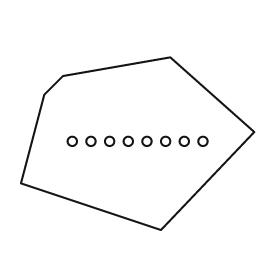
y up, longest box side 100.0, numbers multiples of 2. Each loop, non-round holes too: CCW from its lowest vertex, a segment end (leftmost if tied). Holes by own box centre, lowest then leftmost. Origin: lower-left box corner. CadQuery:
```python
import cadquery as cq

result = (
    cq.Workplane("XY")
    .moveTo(60.0, 0.0)
    .lineTo(100.0, 42.0)
    .lineTo(64.0, 74.0)
    .lineTo(18.0, 66.0)
    .lineTo(10.0, 58.0)
    .lineTo(0.0, 20.0)
    .close()
    .moveTo(22.0, 38.0)
    .circle(2.0)
    .moveTo(30.0, 38.0)
    .circle(2.0)
    .moveTo(38.0, 38.0)
    .circle(2.0)
    .moveTo(46.0, 38.0)
    .circle(2.0)
    .moveTo(54.0, 38.0)
    .circle(2.0)
    .moveTo(62.0, 38.0)
    .circle(2.0)
    .moveTo(70.0, 38.0)
    .circle(2.0)
    .moveTo(78.0, 38.0)
    .circle(2.0)
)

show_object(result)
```